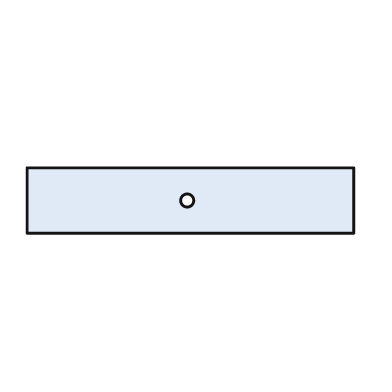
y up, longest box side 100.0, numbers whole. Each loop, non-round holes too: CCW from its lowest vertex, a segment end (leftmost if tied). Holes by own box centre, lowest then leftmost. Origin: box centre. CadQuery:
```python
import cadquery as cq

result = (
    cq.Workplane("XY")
    .moveTo(-50.0, -10.0)
    .lineTo(50.0, -10.0)
    .lineTo(50.0, 10.0)
    .lineTo(-50.0, 10.0)
    .close()
    .moveTo(-1.0, 0.0)
    .circle(2.0)
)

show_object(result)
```